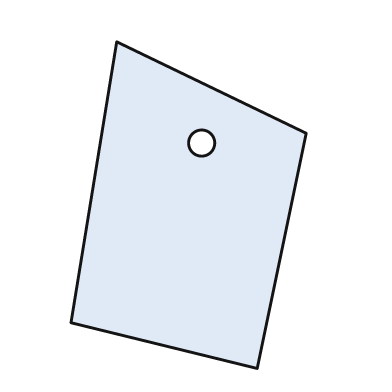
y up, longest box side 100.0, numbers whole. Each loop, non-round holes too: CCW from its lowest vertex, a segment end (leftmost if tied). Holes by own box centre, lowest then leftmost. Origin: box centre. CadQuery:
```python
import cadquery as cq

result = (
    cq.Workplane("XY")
    .moveTo(21.0, -50.0)
    .lineTo(36.0, 22.0)
    .lineTo(-22.0, 50.0)
    .lineTo(-36.0, -36.0)
    .close()
    .moveTo(4.0, 19.0)
    .circle(4.0)
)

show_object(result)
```